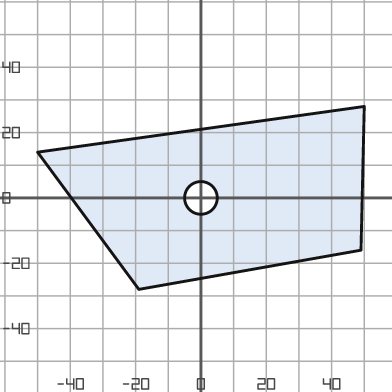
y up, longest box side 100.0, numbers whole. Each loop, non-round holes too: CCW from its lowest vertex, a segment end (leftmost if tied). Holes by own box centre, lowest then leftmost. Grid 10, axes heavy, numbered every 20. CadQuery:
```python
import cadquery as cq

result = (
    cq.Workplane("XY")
    .moveTo(-19.0, -28.0)
    .lineTo(49.0, -16.0)
    .lineTo(50.0, 28.0)
    .lineTo(-50.0, 14.0)
    .close()
    .moveTo(0.0, 0.0)
    .circle(5.0)
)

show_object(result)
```